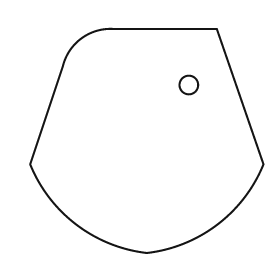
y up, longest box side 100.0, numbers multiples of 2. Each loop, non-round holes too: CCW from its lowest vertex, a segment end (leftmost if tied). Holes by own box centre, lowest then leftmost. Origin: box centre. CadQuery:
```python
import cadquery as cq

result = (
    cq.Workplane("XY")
    .moveTo(0.0, -48.0)
    .threePointArc((30.0, -36.0), (50.0, -10.0))
    .lineTo(30.0, 48.0)
    .lineTo(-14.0, 48.0)
    .threePointArc((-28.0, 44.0), (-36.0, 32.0))
    .lineTo(-50.0, -10.0)
    .threePointArc((-30.0, -36.0), (0.0, -48.0))
    .close()
    .moveTo(18.0, 24.0)
    .circle(4.0)
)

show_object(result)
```